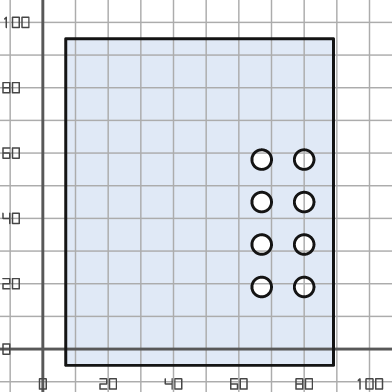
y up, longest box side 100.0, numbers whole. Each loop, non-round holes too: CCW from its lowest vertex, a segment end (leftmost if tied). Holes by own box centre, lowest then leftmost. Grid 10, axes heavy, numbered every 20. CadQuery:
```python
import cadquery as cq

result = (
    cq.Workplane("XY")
    .moveTo(7.0, -5.0)
    .lineTo(89.0, -5.0)
    .lineTo(89.0, 95.0)
    .lineTo(7.0, 95.0)
    .close()
    .moveTo(67.0, 19.0)
    .circle(3.0)
    .moveTo(80.0, 19.0)
    .circle(3.0)
    .moveTo(67.0, 32.0)
    .circle(3.0)
    .moveTo(80.0, 32.0)
    .circle(3.0)
    .moveTo(67.0, 45.0)
    .circle(3.0)
    .moveTo(80.0, 45.0)
    .circle(3.0)
    .moveTo(67.0, 58.0)
    .circle(3.0)
    .moveTo(80.0, 58.0)
    .circle(3.0)
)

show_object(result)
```